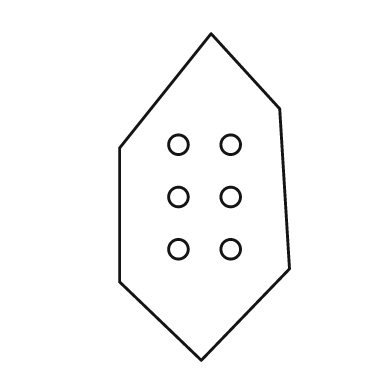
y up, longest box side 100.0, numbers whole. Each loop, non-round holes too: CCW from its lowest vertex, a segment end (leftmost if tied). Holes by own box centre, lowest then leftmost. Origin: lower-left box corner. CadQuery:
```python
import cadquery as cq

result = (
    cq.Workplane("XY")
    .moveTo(25.0, 0.0)
    .lineTo(52.0, 28.0)
    .lineTo(49.0, 77.0)
    .lineTo(28.0, 100.0)
    .lineTo(0.0, 65.0)
    .lineTo(0.0, 24.0)
    .close()
    .moveTo(18.0, 34.0)
    .circle(3.0)
    .moveTo(34.0, 34.0)
    .circle(3.0)
    .moveTo(18.0, 50.0)
    .circle(3.0)
    .moveTo(34.0, 50.0)
    .circle(3.0)
    .moveTo(18.0, 66.0)
    .circle(3.0)
    .moveTo(34.0, 66.0)
    .circle(3.0)
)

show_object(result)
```